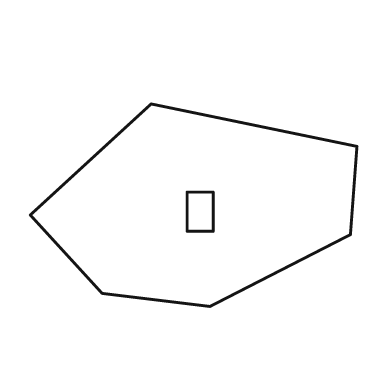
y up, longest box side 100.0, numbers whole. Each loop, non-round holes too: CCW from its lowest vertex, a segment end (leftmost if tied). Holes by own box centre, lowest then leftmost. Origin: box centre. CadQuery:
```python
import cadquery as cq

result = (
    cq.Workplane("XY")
    .moveTo(5.0, -31.0)
    .lineTo(48.0, -9.0)
    .lineTo(50.0, 18.0)
    .lineTo(-13.0, 31.0)
    .lineTo(-50.0, -3.0)
    .lineTo(-28.0, -27.0)
    .close()
    .moveTo(-2.0, -8.0)
    .lineTo(6.0, -8.0)
    .lineTo(6.0, 4.0)
    .lineTo(-2.0, 4.0)
    .close()
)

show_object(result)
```